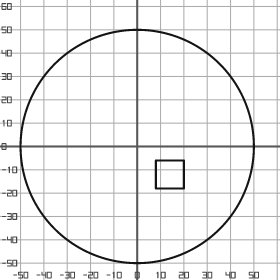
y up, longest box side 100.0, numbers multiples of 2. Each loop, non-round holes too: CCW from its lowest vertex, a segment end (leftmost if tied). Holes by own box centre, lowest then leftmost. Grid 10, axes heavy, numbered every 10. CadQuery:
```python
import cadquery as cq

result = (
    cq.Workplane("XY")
    .moveTo(0.0, 0.0)
    .circle(50.0)
    .moveTo(8.0, -18.0)
    .lineTo(20.0, -18.0)
    .lineTo(20.0, -6.0)
    .lineTo(8.0, -6.0)
    .close()
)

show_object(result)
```